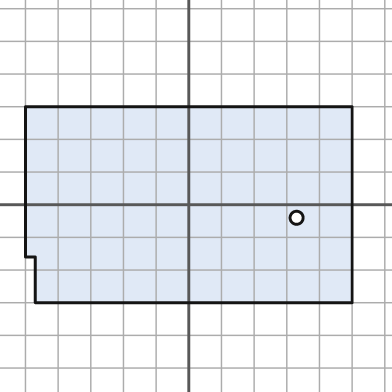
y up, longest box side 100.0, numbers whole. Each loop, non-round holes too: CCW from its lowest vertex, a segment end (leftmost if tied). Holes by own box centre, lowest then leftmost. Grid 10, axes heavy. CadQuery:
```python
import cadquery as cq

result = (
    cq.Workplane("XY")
    .moveTo(-47.0, -30.0)
    .lineTo(50.0, -30.0)
    .lineTo(50.0, 30.0)
    .lineTo(-50.0, 30.0)
    .lineTo(-50.0, -16.0)
    .lineTo(-47.0, -16.0)
    .close()
    .moveTo(33.0, -4.0)
    .circle(2.0)
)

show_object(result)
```